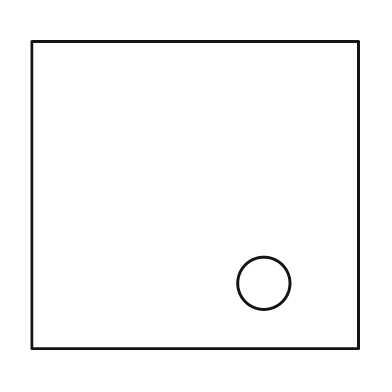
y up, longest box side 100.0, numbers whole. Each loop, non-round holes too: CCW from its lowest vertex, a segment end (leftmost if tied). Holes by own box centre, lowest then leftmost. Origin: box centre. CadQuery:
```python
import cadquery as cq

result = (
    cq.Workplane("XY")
    .moveTo(-50.0, -47.0)
    .lineTo(50.0, -47.0)
    .lineTo(50.0, 47.0)
    .lineTo(-50.0, 47.0)
    .close()
    .moveTo(21.0, -27.0)
    .circle(8.0)
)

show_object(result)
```